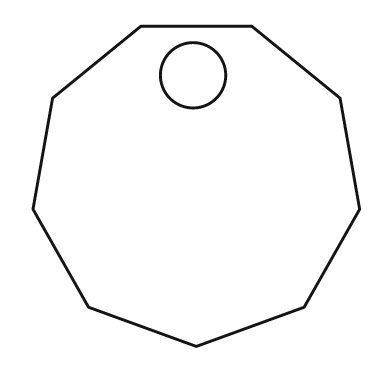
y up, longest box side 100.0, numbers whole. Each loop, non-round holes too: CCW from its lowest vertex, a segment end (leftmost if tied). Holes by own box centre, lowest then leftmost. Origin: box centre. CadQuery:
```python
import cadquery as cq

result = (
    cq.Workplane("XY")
    .moveTo(0.0, -49.0)
    .lineTo(33.0, -37.0)
    .lineTo(50.0, -7.0)
    .lineTo(44.0, 27.0)
    .lineTo(17.0, 49.0)
    .lineTo(-17.0, 49.0)
    .lineTo(-44.0, 27.0)
    .lineTo(-50.0, -7.0)
    .lineTo(-33.0, -37.0)
    .close()
    .moveTo(-1.0, 34.0)
    .circle(10.0)
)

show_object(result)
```